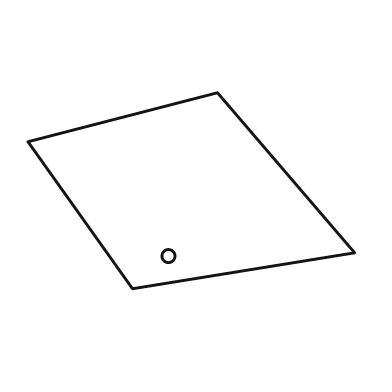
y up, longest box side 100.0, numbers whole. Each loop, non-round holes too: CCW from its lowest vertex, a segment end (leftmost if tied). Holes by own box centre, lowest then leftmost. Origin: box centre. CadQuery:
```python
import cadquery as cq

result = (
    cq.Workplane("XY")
    .moveTo(-18.0, -30.0)
    .lineTo(50.0, -19.0)
    .lineTo(8.0, 30.0)
    .lineTo(-50.0, 15.0)
    .close()
    .moveTo(-7.0, -20.0)
    .circle(2.0)
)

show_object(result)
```